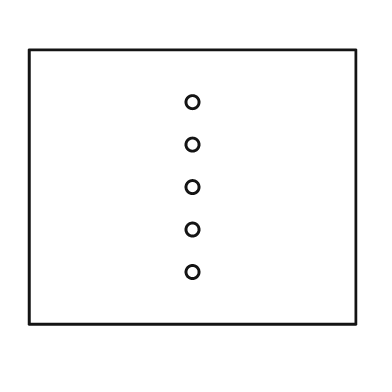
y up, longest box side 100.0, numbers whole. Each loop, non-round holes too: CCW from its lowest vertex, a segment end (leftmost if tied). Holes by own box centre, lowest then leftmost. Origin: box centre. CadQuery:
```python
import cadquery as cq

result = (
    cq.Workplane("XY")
    .moveTo(-50.0, -42.0)
    .lineTo(50.0, -42.0)
    .lineTo(50.0, 42.0)
    .lineTo(-50.0, 42.0)
    .close()
    .moveTo(0.0, -26.0)
    .circle(2.0)
    .moveTo(0.0, -13.0)
    .circle(2.0)
    .moveTo(0.0, 0.0)
    .circle(2.0)
    .moveTo(0.0, 13.0)
    .circle(2.0)
    .moveTo(0.0, 26.0)
    .circle(2.0)
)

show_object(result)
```